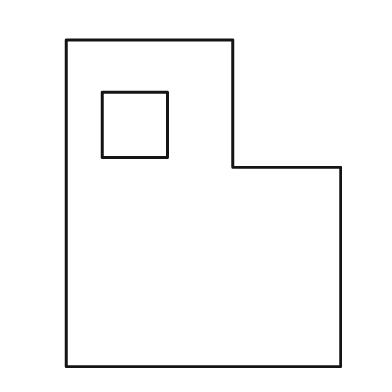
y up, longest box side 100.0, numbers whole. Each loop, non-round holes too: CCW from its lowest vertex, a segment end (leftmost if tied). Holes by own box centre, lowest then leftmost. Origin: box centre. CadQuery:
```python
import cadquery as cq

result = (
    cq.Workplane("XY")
    .moveTo(-42.0, -50.0)
    .lineTo(42.0, -50.0)
    .lineTo(42.0, 11.0)
    .lineTo(9.0, 11.0)
    .lineTo(9.0, 50.0)
    .lineTo(-42.0, 50.0)
    .close()
    .moveTo(-31.0, 14.0)
    .lineTo(-11.0, 14.0)
    .lineTo(-11.0, 34.0)
    .lineTo(-31.0, 34.0)
    .close()
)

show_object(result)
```